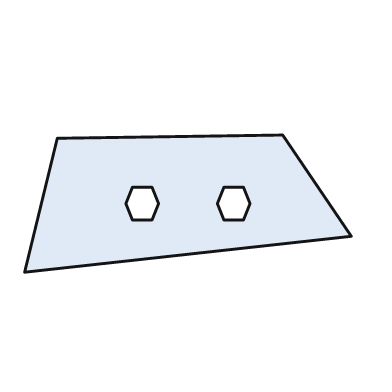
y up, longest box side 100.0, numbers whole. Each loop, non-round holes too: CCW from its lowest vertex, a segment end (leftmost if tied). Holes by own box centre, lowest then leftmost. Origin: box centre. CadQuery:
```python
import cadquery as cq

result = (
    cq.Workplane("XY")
    .moveTo(-50.0, -21.0)
    .lineTo(50.0, -10.0)
    .lineTo(29.0, 21.0)
    .lineTo(-40.0, 20.0)
    .close()
    .moveTo(-17.0, -5.0)
    .lineTo(-11.0, -5.0)
    .lineTo(-9.0, 0.0)
    .lineTo(-11.0, 5.0)
    .lineTo(-17.0, 5.0)
    .lineTo(-19.0, 0.0)
    .close()
    .moveTo(11.0, -5.0)
    .lineTo(17.0, -5.0)
    .lineTo(19.0, 0.0)
    .lineTo(17.0, 5.0)
    .lineTo(11.0, 5.0)
    .lineTo(9.0, 0.0)
    .close()
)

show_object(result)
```